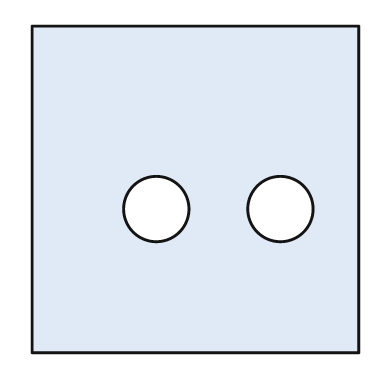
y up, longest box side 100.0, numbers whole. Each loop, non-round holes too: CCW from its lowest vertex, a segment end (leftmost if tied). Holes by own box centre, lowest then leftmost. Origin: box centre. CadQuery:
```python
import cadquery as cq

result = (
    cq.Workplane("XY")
    .moveTo(-50.0, -50.0)
    .lineTo(50.0, -50.0)
    .lineTo(50.0, 50.0)
    .lineTo(-50.0, 50.0)
    .close()
    .moveTo(-12.0, -6.0)
    .circle(10.0)
    .moveTo(26.0, -6.0)
    .circle(10.0)
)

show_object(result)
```